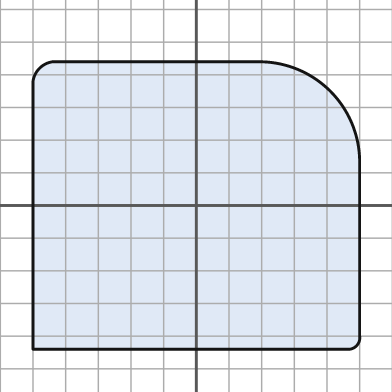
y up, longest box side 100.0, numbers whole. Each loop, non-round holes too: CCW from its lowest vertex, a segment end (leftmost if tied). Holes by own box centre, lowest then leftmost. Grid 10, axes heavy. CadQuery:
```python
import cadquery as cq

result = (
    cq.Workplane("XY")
    .moveTo(-50.0, -44.0)
    .lineTo(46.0, -44.0)
    .threePointArc((49.0, -43.0), (50.0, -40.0))
    .lineTo(50.0, 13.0)
    .threePointArc((41.0, 35.0), (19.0, 44.0))
    .lineTo(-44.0, 44.0)
    .threePointArc((-48.0, 42.0), (-50.0, 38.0))
    .close()
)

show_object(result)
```